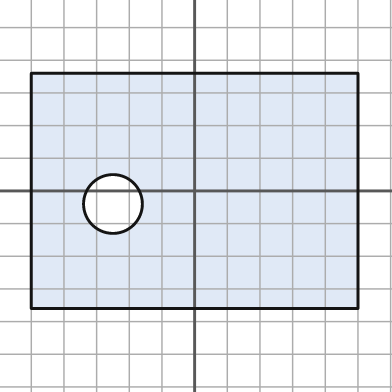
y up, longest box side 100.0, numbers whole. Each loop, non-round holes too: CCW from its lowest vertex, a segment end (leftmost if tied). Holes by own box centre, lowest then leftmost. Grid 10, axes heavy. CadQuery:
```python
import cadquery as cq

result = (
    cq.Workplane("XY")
    .moveTo(-50.0, -36.0)
    .lineTo(50.0, -36.0)
    .lineTo(50.0, 36.0)
    .lineTo(-50.0, 36.0)
    .close()
    .moveTo(-25.0, -4.0)
    .circle(9.0)
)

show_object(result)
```